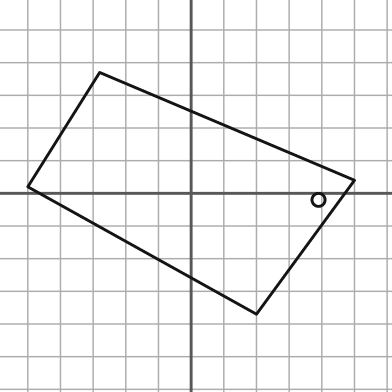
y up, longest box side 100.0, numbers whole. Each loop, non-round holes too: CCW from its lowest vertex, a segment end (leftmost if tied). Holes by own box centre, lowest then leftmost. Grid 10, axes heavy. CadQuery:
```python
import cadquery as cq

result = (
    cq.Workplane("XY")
    .moveTo(20.0, -37.0)
    .lineTo(50.0, 4.0)
    .lineTo(-28.0, 37.0)
    .lineTo(-50.0, 2.0)
    .close()
    .moveTo(39.0, -2.0)
    .circle(2.0)
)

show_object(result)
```